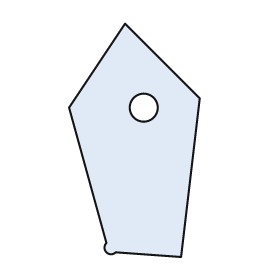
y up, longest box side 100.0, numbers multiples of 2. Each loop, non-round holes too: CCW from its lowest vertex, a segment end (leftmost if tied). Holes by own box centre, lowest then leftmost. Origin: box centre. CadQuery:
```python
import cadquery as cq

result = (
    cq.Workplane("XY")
    .moveTo(20.0, -50.0)
    .lineTo(28.0, 18.0)
    .lineTo(-4.0, 50.0)
    .lineTo(-28.0, 14.0)
    .lineTo(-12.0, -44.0)
    .threePointArc((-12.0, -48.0), (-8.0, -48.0))
    .close()
    .moveTo(4.0, 14.0)
    .circle(6.0)
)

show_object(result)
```